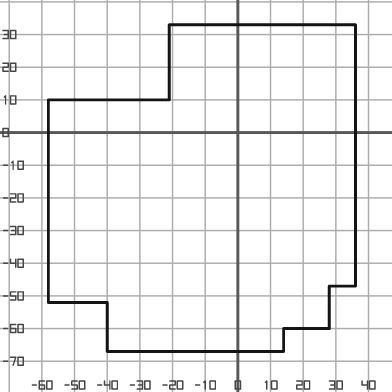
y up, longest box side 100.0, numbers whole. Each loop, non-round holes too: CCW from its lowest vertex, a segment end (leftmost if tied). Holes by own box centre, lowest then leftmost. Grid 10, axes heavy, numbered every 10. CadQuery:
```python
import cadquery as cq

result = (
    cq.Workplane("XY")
    .moveTo(-40.0, -67.0)
    .lineTo(14.0, -67.0)
    .lineTo(14.0, -60.0)
    .lineTo(28.0, -60.0)
    .lineTo(28.0, -47.0)
    .lineTo(36.0, -47.0)
    .lineTo(36.0, 33.0)
    .lineTo(-21.0, 33.0)
    .lineTo(-21.0, 10.0)
    .lineTo(-58.0, 10.0)
    .lineTo(-58.0, -52.0)
    .lineTo(-40.0, -52.0)
    .close()
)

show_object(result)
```